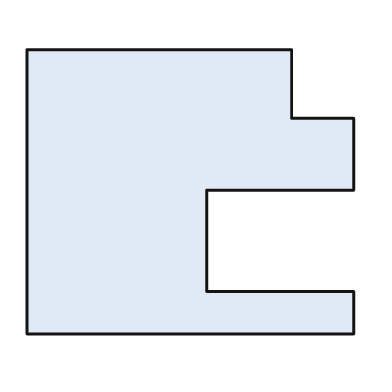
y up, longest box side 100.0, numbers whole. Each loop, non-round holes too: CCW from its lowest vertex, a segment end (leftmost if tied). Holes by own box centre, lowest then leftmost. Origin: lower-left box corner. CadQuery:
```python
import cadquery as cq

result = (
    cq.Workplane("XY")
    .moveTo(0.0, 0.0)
    .lineTo(100.0, 0.0)
    .lineTo(100.0, 13.0)
    .lineTo(55.0, 13.0)
    .lineTo(55.0, 44.0)
    .lineTo(100.0, 44.0)
    .lineTo(100.0, 66.0)
    .lineTo(81.0, 66.0)
    .lineTo(81.0, 87.0)
    .lineTo(0.0, 87.0)
    .close()
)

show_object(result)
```